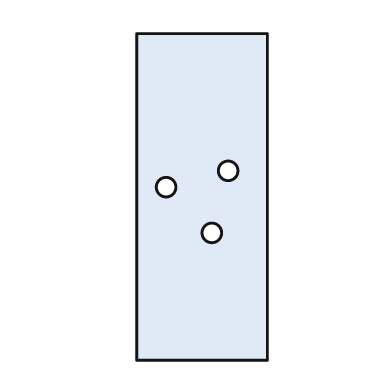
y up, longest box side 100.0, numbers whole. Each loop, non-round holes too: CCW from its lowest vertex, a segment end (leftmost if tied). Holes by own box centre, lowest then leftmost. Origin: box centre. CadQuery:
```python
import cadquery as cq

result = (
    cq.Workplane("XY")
    .moveTo(-20.0, -50.0)
    .lineTo(20.0, -50.0)
    .lineTo(20.0, 50.0)
    .lineTo(-20.0, 50.0)
    .close()
    .moveTo(3.0, -11.0)
    .circle(3.0)
    .moveTo(-11.0, 3.0)
    .circle(3.0)
    .moveTo(8.0, 8.0)
    .circle(3.0)
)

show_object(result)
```